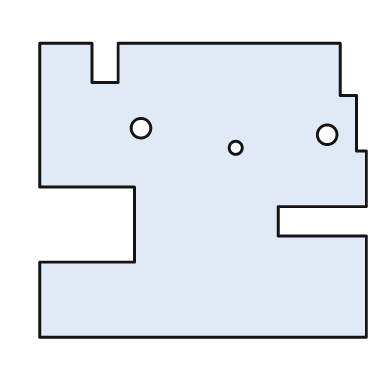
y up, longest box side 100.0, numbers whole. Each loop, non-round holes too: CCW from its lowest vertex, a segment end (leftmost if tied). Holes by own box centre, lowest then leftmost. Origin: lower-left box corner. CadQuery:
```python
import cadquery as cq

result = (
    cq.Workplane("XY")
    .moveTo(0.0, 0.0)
    .lineTo(100.0, 0.0)
    .lineTo(100.0, 31.0)
    .lineTo(73.0, 31.0)
    .lineTo(73.0, 40.0)
    .lineTo(100.0, 40.0)
    .lineTo(100.0, 57.0)
    .lineTo(97.0, 57.0)
    .lineTo(97.0, 74.0)
    .lineTo(92.0, 74.0)
    .lineTo(92.0, 90.0)
    .lineTo(24.0, 90.0)
    .lineTo(24.0, 78.0)
    .lineTo(16.0, 78.0)
    .lineTo(16.0, 90.0)
    .lineTo(0.0, 90.0)
    .lineTo(0.0, 46.0)
    .lineTo(29.0, 46.0)
    .lineTo(29.0, 23.0)
    .lineTo(0.0, 23.0)
    .close()
    .moveTo(60.0, 58.0)
    .circle(2.0)
    .moveTo(88.0, 62.0)
    .circle(3.0)
    .moveTo(31.0, 64.0)
    .circle(3.0)
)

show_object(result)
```